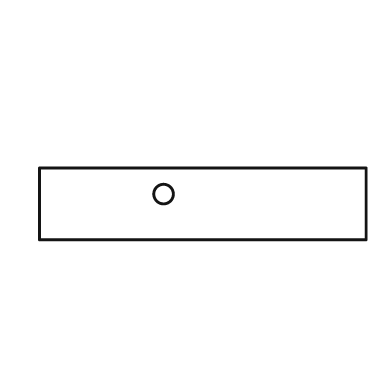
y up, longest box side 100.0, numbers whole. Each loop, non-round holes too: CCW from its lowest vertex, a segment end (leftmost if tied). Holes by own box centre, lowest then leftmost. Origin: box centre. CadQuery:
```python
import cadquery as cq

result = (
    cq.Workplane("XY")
    .moveTo(-50.0, -11.0)
    .lineTo(50.0, -11.0)
    .lineTo(50.0, 11.0)
    .lineTo(-50.0, 11.0)
    .close()
    .moveTo(-12.0, 3.0)
    .circle(3.0)
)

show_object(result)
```